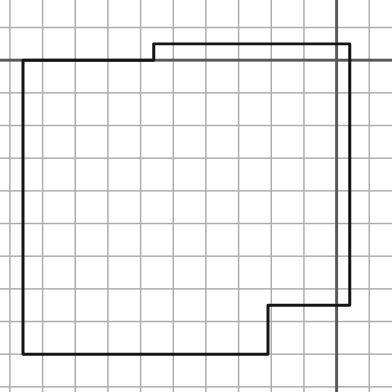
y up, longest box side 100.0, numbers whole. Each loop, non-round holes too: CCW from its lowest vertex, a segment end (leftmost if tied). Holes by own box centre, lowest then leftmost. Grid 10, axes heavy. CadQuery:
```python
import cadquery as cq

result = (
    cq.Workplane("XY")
    .moveTo(-96.0, -90.0)
    .lineTo(-21.0, -90.0)
    .lineTo(-21.0, -75.0)
    .lineTo(4.0, -75.0)
    .lineTo(4.0, 5.0)
    .lineTo(-56.0, 5.0)
    .lineTo(-56.0, 0.0)
    .lineTo(-96.0, 0.0)
    .close()
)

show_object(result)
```